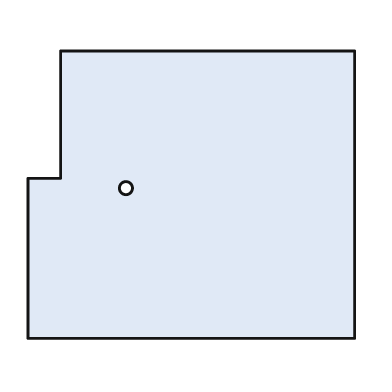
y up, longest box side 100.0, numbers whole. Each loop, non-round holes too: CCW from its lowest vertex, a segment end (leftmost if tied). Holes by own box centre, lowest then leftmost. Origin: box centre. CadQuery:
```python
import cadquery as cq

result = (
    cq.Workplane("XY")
    .moveTo(-50.0, -44.0)
    .lineTo(50.0, -44.0)
    .lineTo(50.0, 44.0)
    .lineTo(-40.0, 44.0)
    .lineTo(-40.0, 5.0)
    .lineTo(-50.0, 5.0)
    .close()
    .moveTo(-20.0, 2.0)
    .circle(2.0)
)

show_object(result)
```